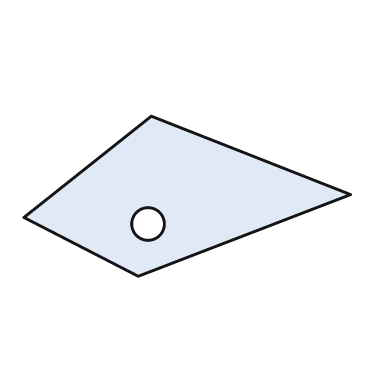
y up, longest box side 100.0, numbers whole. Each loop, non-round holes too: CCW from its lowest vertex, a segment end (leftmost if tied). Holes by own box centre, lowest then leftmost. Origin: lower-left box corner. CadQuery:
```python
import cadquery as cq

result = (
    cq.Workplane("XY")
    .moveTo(35.0, 0.0)
    .lineTo(100.0, 25.0)
    .lineTo(39.0, 49.0)
    .lineTo(0.0, 18.0)
    .close()
    .moveTo(38.0, 16.0)
    .circle(5.0)
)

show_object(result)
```